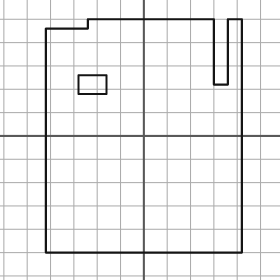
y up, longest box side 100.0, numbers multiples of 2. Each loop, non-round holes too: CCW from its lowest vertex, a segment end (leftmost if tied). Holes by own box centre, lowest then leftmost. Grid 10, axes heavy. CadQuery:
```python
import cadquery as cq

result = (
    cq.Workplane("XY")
    .moveTo(-42.0, -50.0)
    .lineTo(42.0, -50.0)
    .lineTo(42.0, 50.0)
    .lineTo(36.0, 50.0)
    .lineTo(36.0, 22.0)
    .lineTo(30.0, 22.0)
    .lineTo(30.0, 50.0)
    .lineTo(-24.0, 50.0)
    .lineTo(-24.0, 46.0)
    .lineTo(-42.0, 46.0)
    .close()
    .moveTo(-28.0, 18.0)
    .lineTo(-16.0, 18.0)
    .lineTo(-16.0, 26.0)
    .lineTo(-28.0, 26.0)
    .close()
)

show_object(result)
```